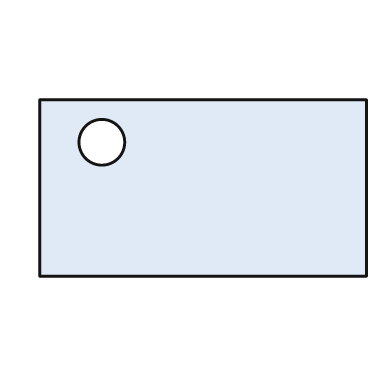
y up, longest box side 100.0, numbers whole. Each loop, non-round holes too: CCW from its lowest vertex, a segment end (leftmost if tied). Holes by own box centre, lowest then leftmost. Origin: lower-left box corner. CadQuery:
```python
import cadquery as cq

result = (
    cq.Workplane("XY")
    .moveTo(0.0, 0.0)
    .lineTo(100.0, 0.0)
    .lineTo(100.0, 54.0)
    .lineTo(0.0, 54.0)
    .close()
    .moveTo(19.0, 41.0)
    .circle(7.0)
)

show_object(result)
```